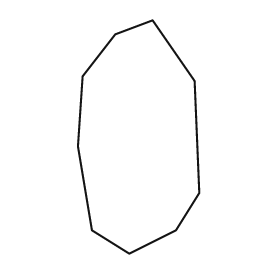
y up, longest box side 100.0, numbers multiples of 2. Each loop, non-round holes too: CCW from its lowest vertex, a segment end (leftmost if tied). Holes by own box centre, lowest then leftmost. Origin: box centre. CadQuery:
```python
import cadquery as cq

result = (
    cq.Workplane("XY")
    .moveTo(-4.0, -50.0)
    .lineTo(16.0, -40.0)
    .lineTo(26.0, -24.0)
    .lineTo(24.0, 24.0)
    .lineTo(6.0, 50.0)
    .lineTo(-10.0, 44.0)
    .lineTo(-24.0, 26.0)
    .lineTo(-26.0, -4.0)
    .lineTo(-20.0, -40.0)
    .close()
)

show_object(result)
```